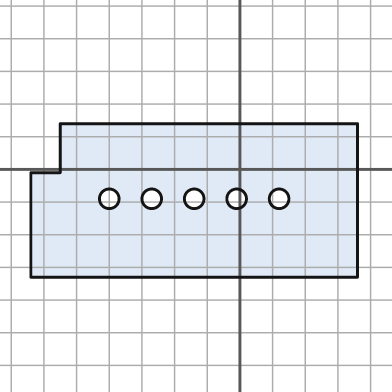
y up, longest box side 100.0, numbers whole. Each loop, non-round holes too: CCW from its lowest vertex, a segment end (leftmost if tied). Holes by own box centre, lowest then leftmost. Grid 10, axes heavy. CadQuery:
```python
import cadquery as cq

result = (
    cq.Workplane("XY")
    .moveTo(-64.0, -33.0)
    .lineTo(36.0, -33.0)
    .lineTo(36.0, 14.0)
    .lineTo(-55.0, 14.0)
    .lineTo(-55.0, -1.0)
    .lineTo(-64.0, -1.0)
    .close()
    .moveTo(-40.0, -9.0)
    .circle(3.0)
    .moveTo(-27.0, -9.0)
    .circle(3.0)
    .moveTo(-14.0, -9.0)
    .circle(3.0)
    .moveTo(-1.0, -9.0)
    .circle(3.0)
    .moveTo(12.0, -9.0)
    .circle(3.0)
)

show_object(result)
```